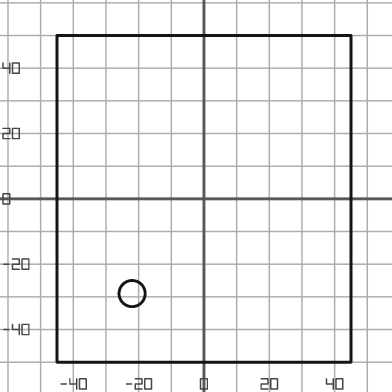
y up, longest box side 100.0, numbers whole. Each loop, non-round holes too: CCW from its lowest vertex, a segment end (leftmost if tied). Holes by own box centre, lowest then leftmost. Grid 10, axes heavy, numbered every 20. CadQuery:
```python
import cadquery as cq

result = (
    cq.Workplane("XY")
    .moveTo(-45.0, -50.0)
    .lineTo(45.0, -50.0)
    .lineTo(45.0, 50.0)
    .lineTo(-45.0, 50.0)
    .close()
    .moveTo(-22.0, -29.0)
    .circle(4.0)
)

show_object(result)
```